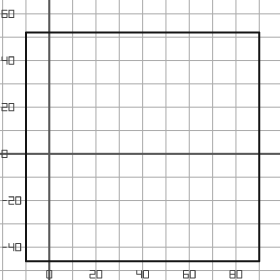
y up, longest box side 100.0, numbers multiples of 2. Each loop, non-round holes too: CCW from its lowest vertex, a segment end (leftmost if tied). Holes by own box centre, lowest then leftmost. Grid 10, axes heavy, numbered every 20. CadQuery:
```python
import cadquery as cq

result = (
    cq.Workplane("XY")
    .moveTo(-10.0, -46.0)
    .lineTo(90.0, -46.0)
    .lineTo(90.0, 52.0)
    .lineTo(-10.0, 52.0)
    .close()
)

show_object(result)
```